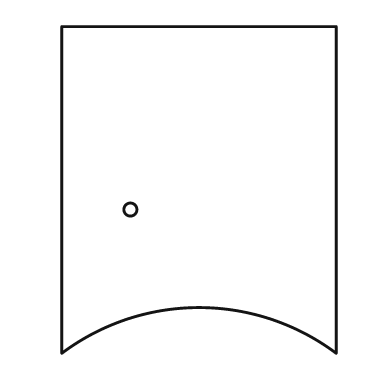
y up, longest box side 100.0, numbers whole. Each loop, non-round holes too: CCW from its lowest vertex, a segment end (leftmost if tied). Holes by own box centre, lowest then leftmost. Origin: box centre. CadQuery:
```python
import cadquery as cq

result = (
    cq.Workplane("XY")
    .moveTo(-42.0, -50.0)
    .threePointArc((0.0, -36.0), (42.0, -50.0))
    .lineTo(42.0, 50.0)
    .lineTo(-42.0, 50.0)
    .close()
    .moveTo(-21.0, -6.0)
    .circle(2.0)
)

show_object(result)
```